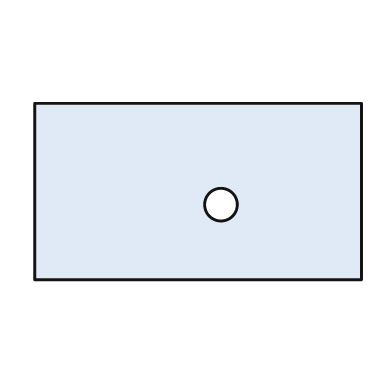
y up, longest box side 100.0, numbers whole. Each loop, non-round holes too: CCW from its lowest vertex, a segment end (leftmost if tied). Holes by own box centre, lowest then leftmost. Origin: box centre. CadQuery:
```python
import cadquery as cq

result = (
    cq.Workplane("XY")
    .moveTo(-50.0, -27.0)
    .lineTo(50.0, -27.0)
    .lineTo(50.0, 27.0)
    .lineTo(-50.0, 27.0)
    .close()
    .moveTo(7.0, -4.0)
    .circle(5.0)
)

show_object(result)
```